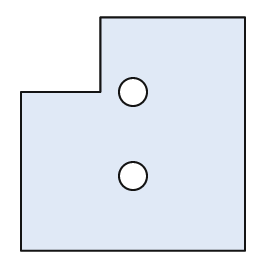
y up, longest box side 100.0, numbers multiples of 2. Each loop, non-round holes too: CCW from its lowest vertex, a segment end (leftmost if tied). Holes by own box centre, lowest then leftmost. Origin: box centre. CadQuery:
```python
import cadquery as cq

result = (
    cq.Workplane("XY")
    .moveTo(-48.0, -50.0)
    .lineTo(48.0, -50.0)
    .lineTo(48.0, 50.0)
    .lineTo(-14.0, 50.0)
    .lineTo(-14.0, 18.0)
    .lineTo(-48.0, 18.0)
    .close()
    .moveTo(0.0, -18.0)
    .circle(6.0)
    .moveTo(0.0, 18.0)
    .circle(6.0)
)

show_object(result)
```